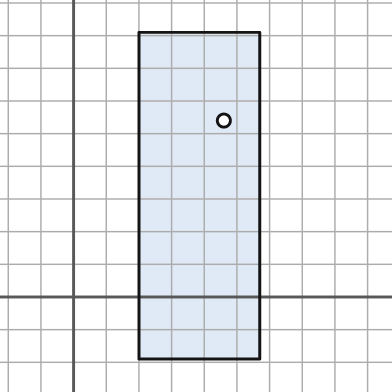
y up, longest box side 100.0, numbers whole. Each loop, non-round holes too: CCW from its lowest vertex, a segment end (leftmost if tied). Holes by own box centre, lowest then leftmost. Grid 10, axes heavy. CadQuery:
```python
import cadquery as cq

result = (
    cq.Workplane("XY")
    .moveTo(20.0, -19.0)
    .lineTo(57.0, -19.0)
    .lineTo(57.0, 81.0)
    .lineTo(20.0, 81.0)
    .close()
    .moveTo(46.0, 54.0)
    .circle(2.0)
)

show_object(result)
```